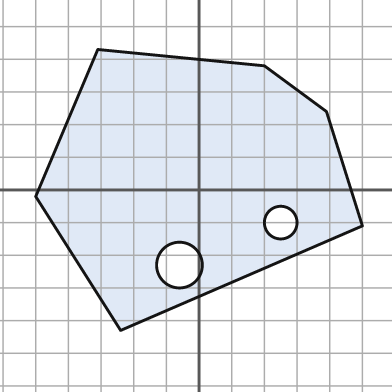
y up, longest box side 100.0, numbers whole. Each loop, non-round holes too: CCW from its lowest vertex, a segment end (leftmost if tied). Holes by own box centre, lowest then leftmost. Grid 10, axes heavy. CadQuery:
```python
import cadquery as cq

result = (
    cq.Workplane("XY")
    .moveTo(-24.0, -43.0)
    .lineTo(50.0, -11.0)
    .lineTo(39.0, 24.0)
    .lineTo(20.0, 38.0)
    .lineTo(-31.0, 43.0)
    .lineTo(-50.0, -2.0)
    .close()
    .moveTo(-6.0, -23.0)
    .circle(7.0)
    .moveTo(25.0, -10.0)
    .circle(5.0)
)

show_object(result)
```